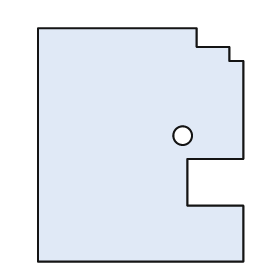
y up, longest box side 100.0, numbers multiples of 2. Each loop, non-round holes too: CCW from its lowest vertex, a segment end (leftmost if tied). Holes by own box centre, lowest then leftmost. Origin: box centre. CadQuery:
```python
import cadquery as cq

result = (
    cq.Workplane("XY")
    .moveTo(-44.0, -50.0)
    .lineTo(44.0, -50.0)
    .lineTo(44.0, -26.0)
    .lineTo(20.0, -26.0)
    .lineTo(20.0, -6.0)
    .lineTo(44.0, -6.0)
    .lineTo(44.0, 36.0)
    .lineTo(38.0, 36.0)
    .lineTo(38.0, 42.0)
    .lineTo(24.0, 42.0)
    .lineTo(24.0, 50.0)
    .lineTo(-44.0, 50.0)
    .close()
    .moveTo(18.0, 4.0)
    .circle(4.0)
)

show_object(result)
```